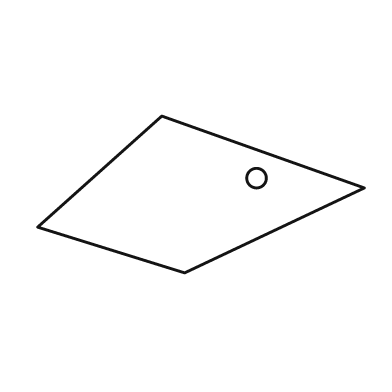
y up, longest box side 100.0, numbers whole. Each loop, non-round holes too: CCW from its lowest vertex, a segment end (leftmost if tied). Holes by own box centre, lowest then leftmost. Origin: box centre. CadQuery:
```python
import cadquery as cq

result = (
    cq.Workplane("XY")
    .moveTo(-5.0, -24.0)
    .lineTo(50.0, 2.0)
    .lineTo(-12.0, 24.0)
    .lineTo(-50.0, -10.0)
    .close()
    .moveTo(17.0, 5.0)
    .circle(3.0)
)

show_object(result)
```